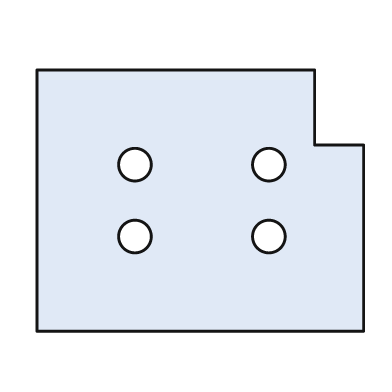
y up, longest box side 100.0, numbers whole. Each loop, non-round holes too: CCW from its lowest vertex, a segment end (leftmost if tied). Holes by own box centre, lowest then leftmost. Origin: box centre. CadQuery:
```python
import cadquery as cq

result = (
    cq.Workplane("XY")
    .moveTo(-50.0, -40.0)
    .lineTo(50.0, -40.0)
    .lineTo(50.0, 17.0)
    .lineTo(35.0, 17.0)
    .lineTo(35.0, 40.0)
    .lineTo(-50.0, 40.0)
    .close()
    .moveTo(-20.0, -11.0)
    .circle(5.0)
    .moveTo(21.0, -11.0)
    .circle(5.0)
    .moveTo(-20.0, 11.0)
    .circle(5.0)
    .moveTo(21.0, 11.0)
    .circle(5.0)
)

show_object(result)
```